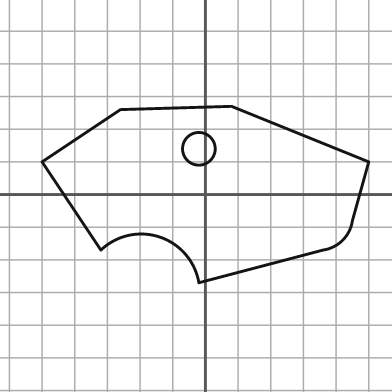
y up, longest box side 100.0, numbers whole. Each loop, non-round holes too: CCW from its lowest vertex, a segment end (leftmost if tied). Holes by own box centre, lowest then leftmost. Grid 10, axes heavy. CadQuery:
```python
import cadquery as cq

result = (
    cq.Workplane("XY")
    .moveTo(-2.0, -27.0)
    .lineTo(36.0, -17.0)
    .threePointArc((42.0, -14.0), (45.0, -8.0))
    .lineTo(50.0, 10.0)
    .lineTo(8.0, 27.0)
    .lineTo(-26.0, 26.0)
    .lineTo(-50.0, 10.0)
    .lineTo(-32.0, -17.0)
    .threePointArc((-14.0, -13.0), (-2.0, -27.0))
    .close()
    .moveTo(-2.0, 14.0)
    .circle(5.0)
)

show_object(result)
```